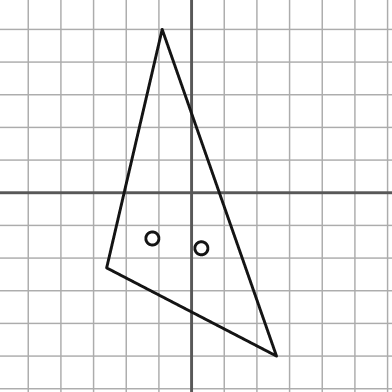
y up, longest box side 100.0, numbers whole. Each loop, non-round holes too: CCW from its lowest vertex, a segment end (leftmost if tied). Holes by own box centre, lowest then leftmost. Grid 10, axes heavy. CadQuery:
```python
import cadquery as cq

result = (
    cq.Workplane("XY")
    .moveTo(26.0, -50.0)
    .lineTo(-9.0, 50.0)
    .lineTo(-26.0, -23.0)
    .close()
    .moveTo(3.0, -17.0)
    .circle(2.0)
    .moveTo(-12.0, -14.0)
    .circle(2.0)
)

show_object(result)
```